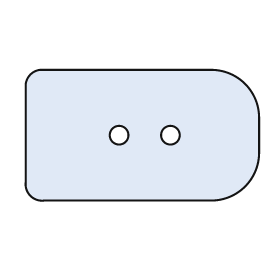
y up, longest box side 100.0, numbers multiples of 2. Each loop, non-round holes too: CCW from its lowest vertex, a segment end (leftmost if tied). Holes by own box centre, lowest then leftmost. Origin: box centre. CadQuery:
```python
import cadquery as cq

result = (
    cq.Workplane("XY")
    .moveTo(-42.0, -28.0)
    .lineTo(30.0, -28.0)
    .threePointArc((44.0, -22.0), (50.0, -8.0))
    .lineTo(50.0, 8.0)
    .threePointArc((44.0, 22.0), (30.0, 28.0))
    .lineTo(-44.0, 28.0)
    .threePointArc((-48.0, 26.0), (-50.0, 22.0))
    .lineTo(-50.0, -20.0)
    .threePointArc((-48.0, -26.0), (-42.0, -28.0))
    .close()
    .moveTo(-10.0, 0.0)
    .circle(4.0)
    .moveTo(12.0, 0.0)
    .circle(4.0)
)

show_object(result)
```